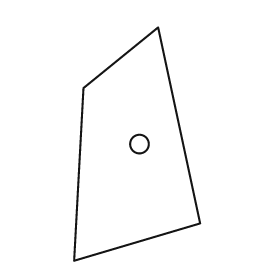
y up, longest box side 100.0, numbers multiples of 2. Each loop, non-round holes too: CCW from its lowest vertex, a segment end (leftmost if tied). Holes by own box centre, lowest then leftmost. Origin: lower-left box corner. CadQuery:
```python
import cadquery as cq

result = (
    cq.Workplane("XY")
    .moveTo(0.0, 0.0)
    .lineTo(54.0, 16.0)
    .lineTo(36.0, 100.0)
    .lineTo(4.0, 74.0)
    .close()
    .moveTo(28.0, 50.0)
    .circle(4.0)
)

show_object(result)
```